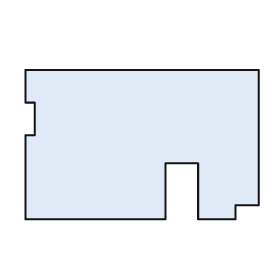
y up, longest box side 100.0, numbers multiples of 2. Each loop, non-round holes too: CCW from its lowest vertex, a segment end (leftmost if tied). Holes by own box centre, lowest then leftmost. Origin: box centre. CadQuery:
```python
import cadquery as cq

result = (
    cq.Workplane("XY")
    .moveTo(-50.0, -32.0)
    .lineTo(10.0, -32.0)
    .lineTo(10.0, -8.0)
    .lineTo(24.0, -8.0)
    .lineTo(24.0, -32.0)
    .lineTo(40.0, -32.0)
    .lineTo(40.0, -26.0)
    .lineTo(50.0, -26.0)
    .lineTo(50.0, 32.0)
    .lineTo(-50.0, 32.0)
    .lineTo(-50.0, 18.0)
    .lineTo(-46.0, 18.0)
    .lineTo(-46.0, 4.0)
    .lineTo(-50.0, 4.0)
    .close()
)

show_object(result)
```